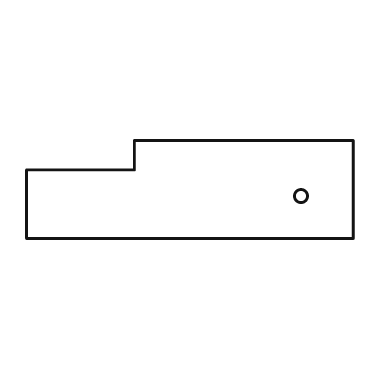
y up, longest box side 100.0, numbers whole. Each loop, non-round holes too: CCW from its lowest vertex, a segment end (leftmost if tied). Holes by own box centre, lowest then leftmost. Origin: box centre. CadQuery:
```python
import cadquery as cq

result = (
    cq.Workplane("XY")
    .moveTo(-50.0, -15.0)
    .lineTo(50.0, -15.0)
    .lineTo(50.0, 15.0)
    .lineTo(-17.0, 15.0)
    .lineTo(-17.0, 6.0)
    .lineTo(-50.0, 6.0)
    .close()
    .moveTo(34.0, -2.0)
    .circle(2.0)
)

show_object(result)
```